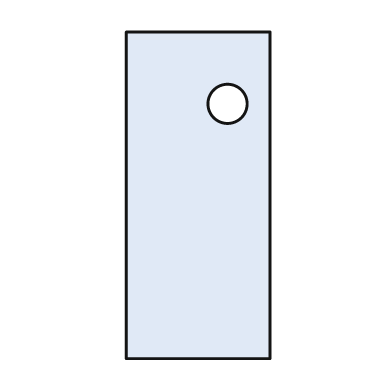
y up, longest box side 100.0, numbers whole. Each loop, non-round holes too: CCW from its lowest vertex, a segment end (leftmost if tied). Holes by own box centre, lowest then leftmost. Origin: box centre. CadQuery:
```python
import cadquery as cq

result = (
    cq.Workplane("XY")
    .moveTo(-22.0, -50.0)
    .lineTo(22.0, -50.0)
    .lineTo(22.0, 50.0)
    .lineTo(-22.0, 50.0)
    .close()
    .moveTo(9.0, 28.0)
    .circle(6.0)
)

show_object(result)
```